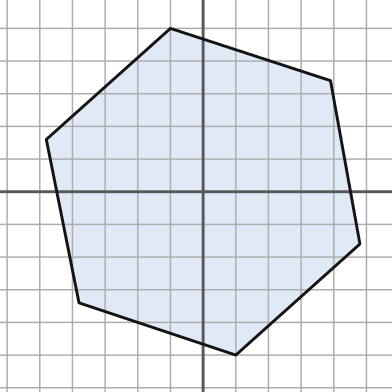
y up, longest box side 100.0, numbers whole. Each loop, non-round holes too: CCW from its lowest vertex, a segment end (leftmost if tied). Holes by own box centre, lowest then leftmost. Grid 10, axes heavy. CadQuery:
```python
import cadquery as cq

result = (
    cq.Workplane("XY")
    .moveTo(10.0, -50.0)
    .lineTo(48.0, -16.0)
    .lineTo(39.0, 34.0)
    .lineTo(-10.0, 50.0)
    .lineTo(-48.0, 16.0)
    .lineTo(-38.0, -34.0)
    .close()
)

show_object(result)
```